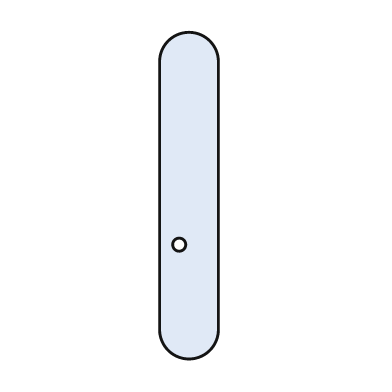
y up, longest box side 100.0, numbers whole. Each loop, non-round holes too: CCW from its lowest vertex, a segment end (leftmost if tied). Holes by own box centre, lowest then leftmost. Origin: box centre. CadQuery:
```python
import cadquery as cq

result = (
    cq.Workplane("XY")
    .moveTo(-9.0, -41.0)
    .threePointArc((0.0, -50.0), (9.0, -41.0))
    .lineTo(9.0, 41.0)
    .threePointArc((0.0, 50.0), (-9.0, 41.0))
    .close()
    .moveTo(-3.0, -15.0)
    .circle(2.0)
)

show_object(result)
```